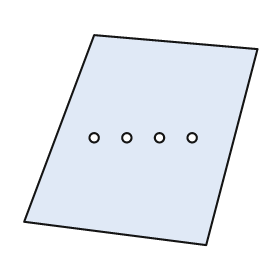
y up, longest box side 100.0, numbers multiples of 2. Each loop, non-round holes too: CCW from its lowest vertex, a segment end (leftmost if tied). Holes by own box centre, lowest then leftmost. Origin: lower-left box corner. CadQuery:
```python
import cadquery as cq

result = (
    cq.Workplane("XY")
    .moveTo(78.0, 0.0)
    .lineTo(100.0, 84.0)
    .lineTo(30.0, 90.0)
    .lineTo(0.0, 10.0)
    .close()
    .moveTo(30.0, 46.0)
    .circle(2.0)
    .moveTo(44.0, 46.0)
    .circle(2.0)
    .moveTo(58.0, 46.0)
    .circle(2.0)
    .moveTo(72.0, 46.0)
    .circle(2.0)
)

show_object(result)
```